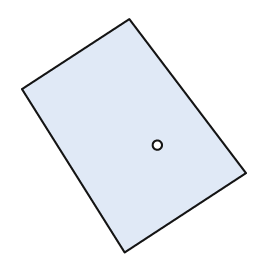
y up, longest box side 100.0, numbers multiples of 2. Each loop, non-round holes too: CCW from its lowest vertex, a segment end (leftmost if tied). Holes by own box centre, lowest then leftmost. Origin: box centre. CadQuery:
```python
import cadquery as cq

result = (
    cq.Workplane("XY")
    .moveTo(-4.0, -50.0)
    .lineTo(48.0, -16.0)
    .lineTo(-2.0, 50.0)
    .lineTo(-48.0, 20.0)
    .close()
    .moveTo(10.0, -4.0)
    .circle(2.0)
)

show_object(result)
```